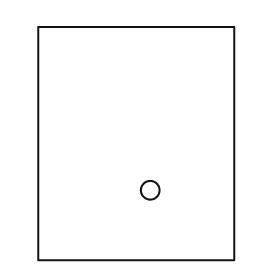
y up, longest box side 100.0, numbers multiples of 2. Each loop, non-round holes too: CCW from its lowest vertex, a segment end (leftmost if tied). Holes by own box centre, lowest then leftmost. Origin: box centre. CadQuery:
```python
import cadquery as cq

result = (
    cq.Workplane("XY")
    .moveTo(-42.0, -50.0)
    .lineTo(42.0, -50.0)
    .lineTo(42.0, 50.0)
    .lineTo(-42.0, 50.0)
    .close()
    .moveTo(6.0, -20.0)
    .circle(4.0)
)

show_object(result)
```